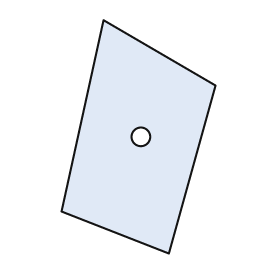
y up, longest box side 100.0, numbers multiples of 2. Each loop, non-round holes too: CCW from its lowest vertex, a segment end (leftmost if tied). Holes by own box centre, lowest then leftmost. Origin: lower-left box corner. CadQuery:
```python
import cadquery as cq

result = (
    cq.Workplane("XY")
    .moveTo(46.0, 0.0)
    .lineTo(66.0, 72.0)
    .lineTo(18.0, 100.0)
    .lineTo(0.0, 18.0)
    .close()
    .moveTo(34.0, 50.0)
    .circle(4.0)
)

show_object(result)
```